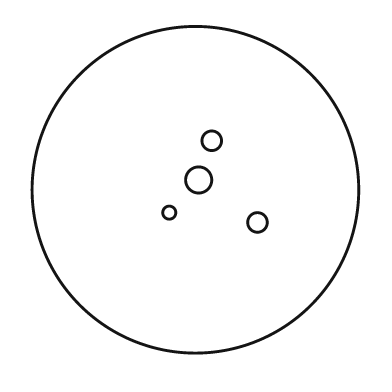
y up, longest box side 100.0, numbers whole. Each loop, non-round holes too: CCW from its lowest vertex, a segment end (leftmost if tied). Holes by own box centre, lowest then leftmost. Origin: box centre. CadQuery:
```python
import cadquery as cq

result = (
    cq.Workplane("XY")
    .moveTo(0.0, 0.0)
    .circle(50.0)
    .moveTo(19.0, -10.0)
    .circle(3.0)
    .moveTo(-8.0, -7.0)
    .circle(2.0)
    .moveTo(1.0, 3.0)
    .circle(4.0)
    .moveTo(5.0, 15.0)
    .circle(3.0)
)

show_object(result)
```